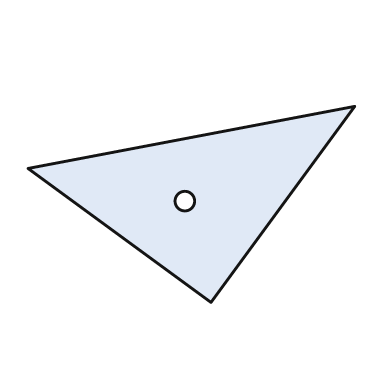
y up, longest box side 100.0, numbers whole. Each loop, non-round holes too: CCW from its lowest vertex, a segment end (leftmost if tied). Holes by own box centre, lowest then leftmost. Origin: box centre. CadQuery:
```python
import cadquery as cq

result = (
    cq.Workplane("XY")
    .moveTo(6.0, -30.0)
    .lineTo(50.0, 30.0)
    .lineTo(-50.0, 11.0)
    .close()
    .moveTo(-2.0, 1.0)
    .circle(3.0)
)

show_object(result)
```